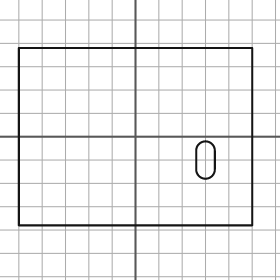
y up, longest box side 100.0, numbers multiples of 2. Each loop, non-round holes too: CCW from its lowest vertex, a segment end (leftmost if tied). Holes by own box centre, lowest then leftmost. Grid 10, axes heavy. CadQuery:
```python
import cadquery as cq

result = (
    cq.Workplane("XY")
    .moveTo(-50.0, -38.0)
    .lineTo(50.0, -38.0)
    .lineTo(50.0, 38.0)
    .lineTo(-50.0, 38.0)
    .close()
    .moveTo(26.0, -14.0)
    .threePointArc((30.0, -18.0), (34.0, -14.0))
    .lineTo(34.0, -6.0)
    .threePointArc((30.0, -2.0), (26.0, -6.0))
    .close()
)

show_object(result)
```